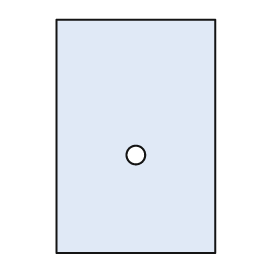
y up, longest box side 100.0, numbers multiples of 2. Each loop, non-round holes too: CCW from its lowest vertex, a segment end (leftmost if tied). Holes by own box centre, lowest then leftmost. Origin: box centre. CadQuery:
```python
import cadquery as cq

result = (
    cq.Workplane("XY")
    .moveTo(-34.0, -50.0)
    .lineTo(34.0, -50.0)
    .lineTo(34.0, 50.0)
    .lineTo(-34.0, 50.0)
    .close()
    .moveTo(0.0, -8.0)
    .circle(4.0)
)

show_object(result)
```